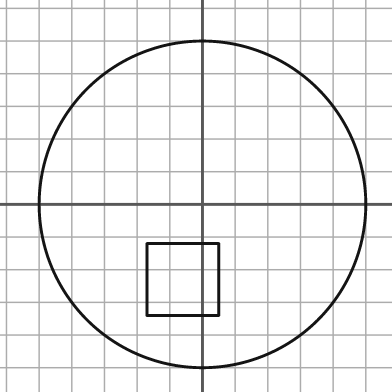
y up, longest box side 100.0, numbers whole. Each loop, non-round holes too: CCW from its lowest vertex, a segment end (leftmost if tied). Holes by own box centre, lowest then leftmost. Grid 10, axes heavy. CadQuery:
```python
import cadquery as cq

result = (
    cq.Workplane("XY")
    .moveTo(0.0, 0.0)
    .circle(50.0)
    .moveTo(-17.0, -34.0)
    .lineTo(5.0, -34.0)
    .lineTo(5.0, -12.0)
    .lineTo(-17.0, -12.0)
    .close()
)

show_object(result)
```